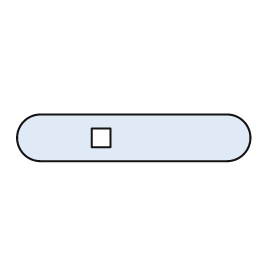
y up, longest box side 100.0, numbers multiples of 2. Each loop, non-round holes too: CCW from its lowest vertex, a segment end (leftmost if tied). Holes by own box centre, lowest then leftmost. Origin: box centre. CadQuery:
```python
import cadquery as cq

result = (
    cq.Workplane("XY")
    .moveTo(-40.0, -10.0)
    .lineTo(40.0, -10.0)
    .threePointArc((50.0, 0.0), (40.0, 10.0))
    .lineTo(-40.0, 10.0)
    .threePointArc((-50.0, 0.0), (-40.0, -10.0))
    .close()
    .moveTo(-18.0, -4.0)
    .lineTo(-10.0, -4.0)
    .lineTo(-10.0, 4.0)
    .lineTo(-18.0, 4.0)
    .close()
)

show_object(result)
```